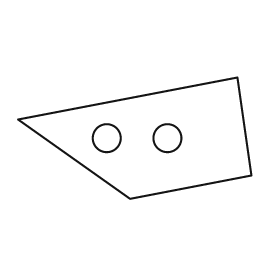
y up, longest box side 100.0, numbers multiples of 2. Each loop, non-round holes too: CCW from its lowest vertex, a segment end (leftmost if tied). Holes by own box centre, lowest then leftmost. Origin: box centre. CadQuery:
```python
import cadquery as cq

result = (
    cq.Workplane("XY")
    .moveTo(-2.0, -26.0)
    .lineTo(50.0, -16.0)
    .lineTo(44.0, 26.0)
    .lineTo(-50.0, 8.0)
    .close()
    .moveTo(-12.0, 0.0)
    .circle(6.0)
    .moveTo(14.0, 0.0)
    .circle(6.0)
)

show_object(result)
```